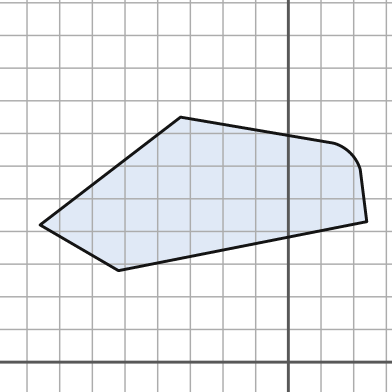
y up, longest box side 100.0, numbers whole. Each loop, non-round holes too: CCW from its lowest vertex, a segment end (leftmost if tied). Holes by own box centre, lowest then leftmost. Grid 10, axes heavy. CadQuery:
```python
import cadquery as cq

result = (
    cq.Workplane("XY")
    .moveTo(-52.0, 28.0)
    .lineTo(24.0, 43.0)
    .lineTo(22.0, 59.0)
    .threePointArc((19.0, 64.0), (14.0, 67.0))
    .lineTo(-33.0, 75.0)
    .lineTo(-76.0, 42.0)
    .close()
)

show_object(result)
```